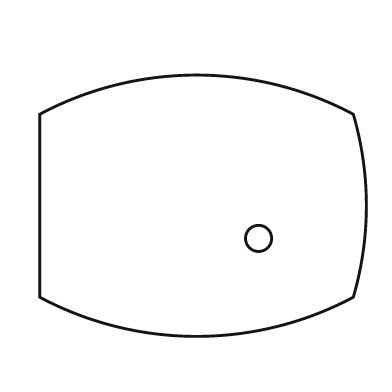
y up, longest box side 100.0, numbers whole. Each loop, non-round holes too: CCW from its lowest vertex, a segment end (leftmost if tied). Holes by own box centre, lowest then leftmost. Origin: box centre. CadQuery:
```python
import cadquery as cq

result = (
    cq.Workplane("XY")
    .moveTo(-50.0, -28.0)
    .threePointArc((-2.0, -40.0), (46.0, -28.0))
    .threePointArc((50.0, 0.0), (46.0, 28.0))
    .threePointArc((-2.0, 40.0), (-50.0, 28.0))
    .close()
    .moveTo(17.0, -10.0)
    .circle(4.0)
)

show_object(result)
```